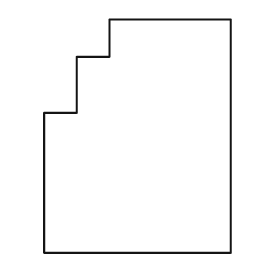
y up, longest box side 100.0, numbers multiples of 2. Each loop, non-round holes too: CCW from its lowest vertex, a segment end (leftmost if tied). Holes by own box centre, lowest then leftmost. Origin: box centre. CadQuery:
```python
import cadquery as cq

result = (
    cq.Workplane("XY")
    .moveTo(-40.0, -50.0)
    .lineTo(40.0, -50.0)
    .lineTo(40.0, 50.0)
    .lineTo(-12.0, 50.0)
    .lineTo(-12.0, 34.0)
    .lineTo(-26.0, 34.0)
    .lineTo(-26.0, 10.0)
    .lineTo(-40.0, 10.0)
    .close()
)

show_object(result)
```